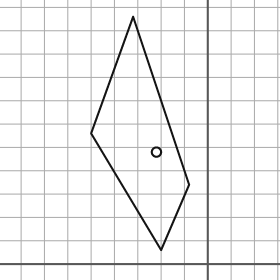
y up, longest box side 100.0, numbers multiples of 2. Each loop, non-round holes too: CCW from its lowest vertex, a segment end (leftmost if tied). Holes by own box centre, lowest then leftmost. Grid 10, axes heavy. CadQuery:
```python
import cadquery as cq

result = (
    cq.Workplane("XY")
    .moveTo(-20.0, 6.0)
    .lineTo(-8.0, 34.0)
    .lineTo(-32.0, 106.0)
    .lineTo(-50.0, 56.0)
    .close()
    .moveTo(-22.0, 48.0)
    .circle(2.0)
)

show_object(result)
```